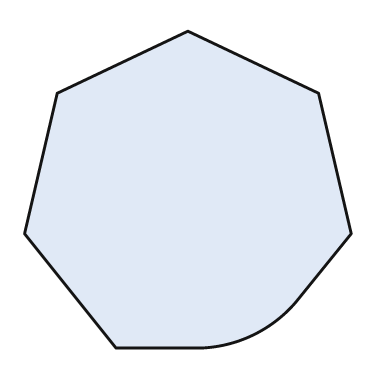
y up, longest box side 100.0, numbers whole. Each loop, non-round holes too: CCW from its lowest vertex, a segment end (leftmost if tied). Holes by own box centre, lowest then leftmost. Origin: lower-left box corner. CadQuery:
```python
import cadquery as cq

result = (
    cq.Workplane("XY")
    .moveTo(28.0, 0.0)
    .lineTo(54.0, 0.0)
    .threePointArc((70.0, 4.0), (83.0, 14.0))
    .lineTo(100.0, 35.0)
    .lineTo(90.0, 78.0)
    .lineTo(50.0, 97.0)
    .lineTo(10.0, 78.0)
    .lineTo(0.0, 35.0)
    .close()
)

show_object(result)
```